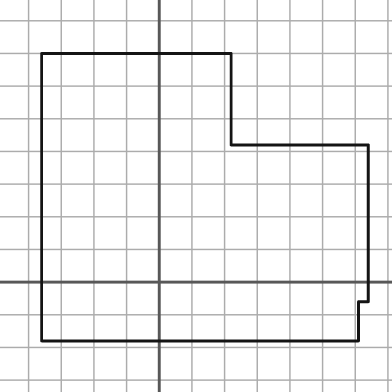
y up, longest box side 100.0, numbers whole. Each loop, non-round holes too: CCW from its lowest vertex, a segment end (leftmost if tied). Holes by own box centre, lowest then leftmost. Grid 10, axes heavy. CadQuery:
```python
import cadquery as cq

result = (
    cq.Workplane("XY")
    .moveTo(-36.0, -18.0)
    .lineTo(61.0, -18.0)
    .lineTo(61.0, -6.0)
    .lineTo(64.0, -6.0)
    .lineTo(64.0, 42.0)
    .lineTo(22.0, 42.0)
    .lineTo(22.0, 70.0)
    .lineTo(-36.0, 70.0)
    .close()
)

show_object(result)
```